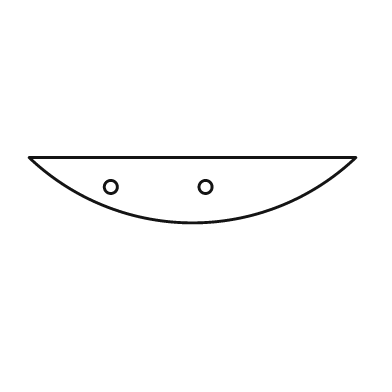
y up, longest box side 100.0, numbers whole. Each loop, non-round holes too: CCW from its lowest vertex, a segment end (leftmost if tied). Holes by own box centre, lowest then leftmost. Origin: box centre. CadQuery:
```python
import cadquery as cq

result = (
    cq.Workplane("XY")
    .moveTo(-50.0, 10.0)
    .threePointArc((0.0, -10.0), (50.0, 10.0))
    .close()
    .moveTo(-25.0, 1.0)
    .circle(2.0)
    .moveTo(4.0, 1.0)
    .circle(2.0)
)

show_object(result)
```